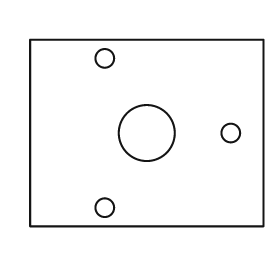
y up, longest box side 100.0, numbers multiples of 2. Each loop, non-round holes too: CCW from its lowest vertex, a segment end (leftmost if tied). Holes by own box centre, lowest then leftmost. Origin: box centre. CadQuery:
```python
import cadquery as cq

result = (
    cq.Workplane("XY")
    .moveTo(-50.0, -40.0)
    .lineTo(50.0, -40.0)
    .lineTo(50.0, 40.0)
    .lineTo(-50.0, 40.0)
    .close()
    .moveTo(-18.0, -32.0)
    .circle(4.0)
    .moveTo(0.0, 0.0)
    .circle(12.0)
    .moveTo(36.0, 0.0)
    .circle(4.0)
    .moveTo(-18.0, 32.0)
    .circle(4.0)
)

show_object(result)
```